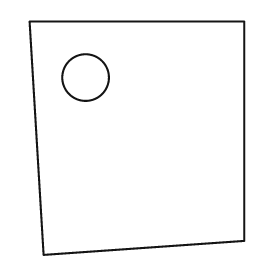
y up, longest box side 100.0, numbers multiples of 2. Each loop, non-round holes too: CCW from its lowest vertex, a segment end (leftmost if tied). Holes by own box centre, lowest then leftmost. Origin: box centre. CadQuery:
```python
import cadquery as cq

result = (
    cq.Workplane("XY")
    .moveTo(-40.0, -50.0)
    .lineTo(46.0, -44.0)
    .lineTo(46.0, 50.0)
    .lineTo(-46.0, 50.0)
    .close()
    .moveTo(-22.0, 26.0)
    .circle(10.0)
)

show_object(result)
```